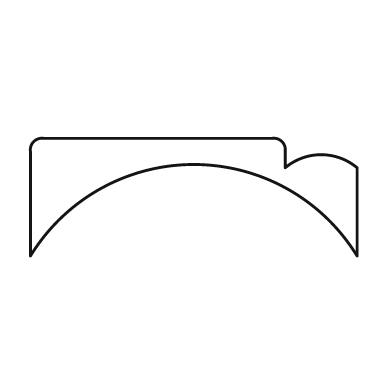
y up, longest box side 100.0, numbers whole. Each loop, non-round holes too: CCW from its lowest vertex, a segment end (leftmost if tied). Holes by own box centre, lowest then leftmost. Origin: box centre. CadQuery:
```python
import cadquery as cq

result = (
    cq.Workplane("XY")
    .moveTo(-50.0, -18.0)
    .threePointArc((0.0, 10.0), (50.0, -18.0))
    .lineTo(50.0, 9.0)
    .threePointArc((39.0, 13.0), (28.0, 9.0))
    .lineTo(28.0, 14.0)
    .threePointArc((27.0, 17.0), (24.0, 18.0))
    .lineTo(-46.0, 18.0)
    .threePointArc((-49.0, 17.0), (-50.0, 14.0))
    .close()
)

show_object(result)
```